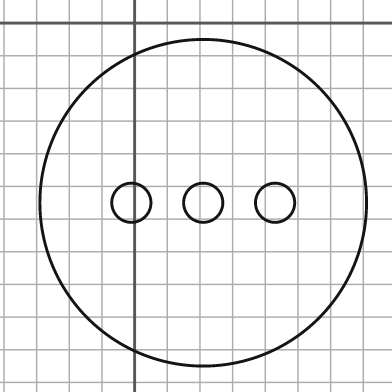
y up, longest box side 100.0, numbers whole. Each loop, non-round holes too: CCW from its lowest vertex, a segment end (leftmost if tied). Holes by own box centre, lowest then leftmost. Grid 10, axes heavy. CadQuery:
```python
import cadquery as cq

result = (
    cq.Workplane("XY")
    .moveTo(21.0, -55.0)
    .circle(50.0)
    .moveTo(-1.0, -55.0)
    .circle(6.0)
    .moveTo(21.0, -55.0)
    .circle(6.0)
    .moveTo(43.0, -55.0)
    .circle(6.0)
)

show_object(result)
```